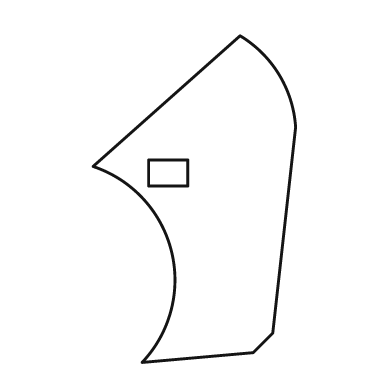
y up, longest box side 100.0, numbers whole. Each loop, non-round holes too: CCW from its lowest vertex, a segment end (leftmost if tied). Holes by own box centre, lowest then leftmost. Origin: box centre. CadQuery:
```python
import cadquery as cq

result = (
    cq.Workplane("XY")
    .moveTo(-16.0, -50.0)
    .lineTo(18.0, -47.0)
    .lineTo(24.0, -41.0)
    .lineTo(31.0, 22.0)
    .threePointArc((26.0, 38.0), (14.0, 50.0))
    .lineTo(-31.0, 10.0)
    .threePointArc((-7.0, -16.0), (-16.0, -50.0))
    .close()
    .moveTo(-14.0, 4.0)
    .lineTo(-2.0, 4.0)
    .lineTo(-2.0, 12.0)
    .lineTo(-14.0, 12.0)
    .close()
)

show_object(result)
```